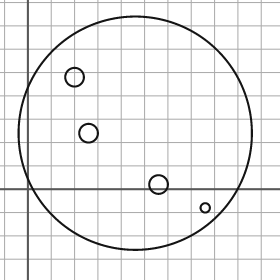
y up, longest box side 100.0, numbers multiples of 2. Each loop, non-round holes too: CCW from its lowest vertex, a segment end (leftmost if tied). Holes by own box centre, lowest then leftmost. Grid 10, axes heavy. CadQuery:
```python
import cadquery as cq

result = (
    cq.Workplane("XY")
    .moveTo(46.0, 24.0)
    .circle(50.0)
    .moveTo(76.0, -8.0)
    .circle(2.0)
    .moveTo(56.0, 2.0)
    .circle(4.0)
    .moveTo(26.0, 24.0)
    .circle(4.0)
    .moveTo(20.0, 48.0)
    .circle(4.0)
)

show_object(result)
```